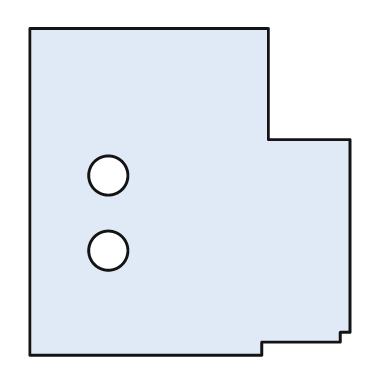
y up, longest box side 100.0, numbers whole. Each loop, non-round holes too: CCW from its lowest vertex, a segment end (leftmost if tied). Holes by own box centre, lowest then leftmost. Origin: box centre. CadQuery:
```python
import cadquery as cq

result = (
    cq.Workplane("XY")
    .moveTo(-49.0, -50.0)
    .lineTo(22.0, -50.0)
    .lineTo(22.0, -46.0)
    .lineTo(46.0, -46.0)
    .lineTo(46.0, -43.0)
    .lineTo(49.0, -43.0)
    .lineTo(49.0, 16.0)
    .lineTo(24.0, 16.0)
    .lineTo(24.0, 50.0)
    .lineTo(-49.0, 50.0)
    .close()
    .moveTo(-25.0, -18.0)
    .circle(6.0)
    .moveTo(-25.0, 5.0)
    .circle(6.0)
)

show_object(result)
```